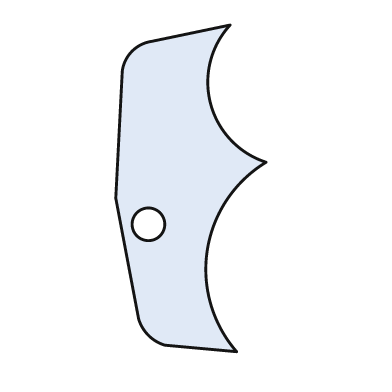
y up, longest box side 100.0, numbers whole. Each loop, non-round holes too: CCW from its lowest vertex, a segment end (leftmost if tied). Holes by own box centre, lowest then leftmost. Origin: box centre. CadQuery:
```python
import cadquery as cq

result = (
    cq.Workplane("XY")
    .moveTo(14.0, -50.0)
    .threePointArc((5.0, -19.0), (23.0, 8.0))
    .threePointArc((6.0, 26.0), (12.0, 50.0))
    .lineTo(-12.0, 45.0)
    .threePointArc((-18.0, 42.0), (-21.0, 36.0))
    .lineTo(-23.0, -3.0)
    .lineTo(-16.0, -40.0)
    .threePointArc((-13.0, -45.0), (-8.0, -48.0))
    .close()
    .moveTo(-13.0, -11.0)
    .circle(5.0)
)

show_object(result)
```